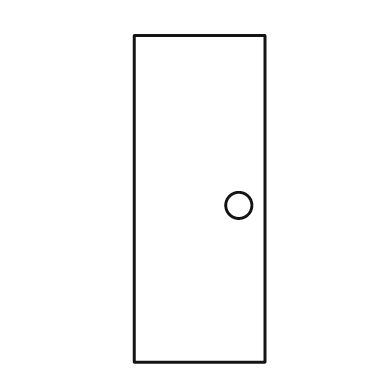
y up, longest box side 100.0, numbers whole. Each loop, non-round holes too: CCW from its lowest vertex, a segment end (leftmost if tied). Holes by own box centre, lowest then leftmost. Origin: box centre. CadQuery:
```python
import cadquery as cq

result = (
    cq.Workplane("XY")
    .moveTo(-20.0, -50.0)
    .lineTo(20.0, -50.0)
    .lineTo(20.0, 50.0)
    .lineTo(-20.0, 50.0)
    .close()
    .moveTo(12.0, -2.0)
    .circle(4.0)
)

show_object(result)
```